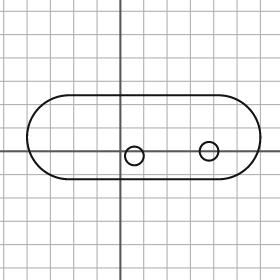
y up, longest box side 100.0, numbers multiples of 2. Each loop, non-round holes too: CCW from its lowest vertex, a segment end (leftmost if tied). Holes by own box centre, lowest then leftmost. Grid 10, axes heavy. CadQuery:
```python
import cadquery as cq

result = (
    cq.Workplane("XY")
    .moveTo(-22.0, -12.0)
    .lineTo(42.0, -12.0)
    .threePointArc((60.0, 6.0), (42.0, 24.0))
    .lineTo(-22.0, 24.0)
    .threePointArc((-40.0, 6.0), (-22.0, -12.0))
    .close()
    .moveTo(6.0, -2.0)
    .circle(4.0)
    .moveTo(38.0, 0.0)
    .circle(4.0)
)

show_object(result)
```